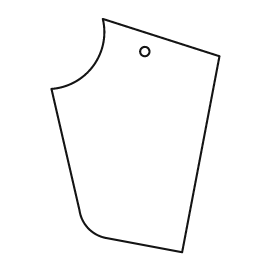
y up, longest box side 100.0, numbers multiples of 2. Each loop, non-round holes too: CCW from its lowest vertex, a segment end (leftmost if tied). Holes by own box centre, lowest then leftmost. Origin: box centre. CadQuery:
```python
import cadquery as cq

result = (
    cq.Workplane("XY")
    .moveTo(20.0, -50.0)
    .lineTo(36.0, 34.0)
    .lineTo(-14.0, 50.0)
    .threePointArc((-18.0, 30.0), (-36.0, 20.0))
    .lineTo(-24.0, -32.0)
    .threePointArc((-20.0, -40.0), (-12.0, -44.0))
    .close()
    .moveTo(4.0, 36.0)
    .circle(2.0)
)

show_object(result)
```